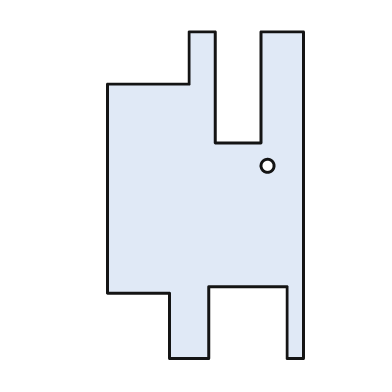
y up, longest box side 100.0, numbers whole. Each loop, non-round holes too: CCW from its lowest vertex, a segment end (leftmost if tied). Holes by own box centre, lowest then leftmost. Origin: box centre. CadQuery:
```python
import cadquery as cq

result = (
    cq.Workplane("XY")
    .moveTo(-11.0, -50.0)
    .lineTo(1.0, -50.0)
    .lineTo(1.0, -28.0)
    .lineTo(25.0, -28.0)
    .lineTo(25.0, -50.0)
    .lineTo(30.0, -50.0)
    .lineTo(30.0, 50.0)
    .lineTo(17.0, 50.0)
    .lineTo(17.0, 16.0)
    .lineTo(3.0, 16.0)
    .lineTo(3.0, 50.0)
    .lineTo(-5.0, 50.0)
    .lineTo(-5.0, 34.0)
    .lineTo(-30.0, 34.0)
    .lineTo(-30.0, -30.0)
    .lineTo(-11.0, -30.0)
    .close()
    .moveTo(19.0, 9.0)
    .circle(2.0)
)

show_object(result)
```